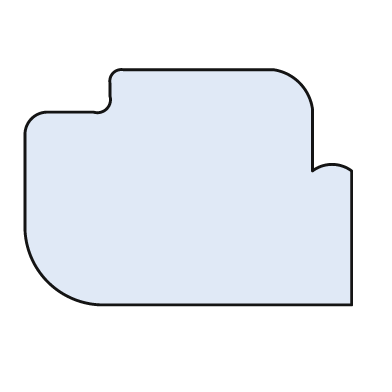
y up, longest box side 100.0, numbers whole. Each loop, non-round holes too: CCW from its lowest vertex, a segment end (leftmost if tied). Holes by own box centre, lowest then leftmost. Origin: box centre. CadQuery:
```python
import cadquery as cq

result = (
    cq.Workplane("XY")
    .moveTo(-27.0, -36.0)
    .lineTo(50.0, -36.0)
    .lineTo(50.0, 5.0)
    .threePointArc((44.0, 7.0), (38.0, 5.0))
    .lineTo(38.0, 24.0)
    .threePointArc((34.0, 32.0), (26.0, 36.0))
    .lineTo(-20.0, 36.0)
    .threePointArc((-23.0, 35.0), (-24.0, 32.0))
    .lineTo(-24.0, 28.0)
    .threePointArc((-25.0, 24.0), (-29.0, 23.0))
    .lineTo(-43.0, 23.0)
    .threePointArc((-48.0, 21.0), (-50.0, 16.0))
    .lineTo(-50.0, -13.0)
    .threePointArc((-43.0, -29.0), (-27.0, -36.0))
    .close()
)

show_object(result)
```